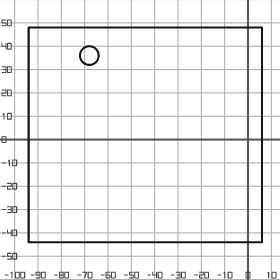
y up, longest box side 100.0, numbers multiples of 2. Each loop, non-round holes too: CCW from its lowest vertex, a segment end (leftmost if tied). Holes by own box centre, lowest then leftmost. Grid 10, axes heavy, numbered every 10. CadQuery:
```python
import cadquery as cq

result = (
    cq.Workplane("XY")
    .moveTo(-94.0, -44.0)
    .lineTo(6.0, -44.0)
    .lineTo(6.0, 48.0)
    .lineTo(-94.0, 48.0)
    .close()
    .moveTo(-68.0, 36.0)
    .circle(4.0)
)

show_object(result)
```